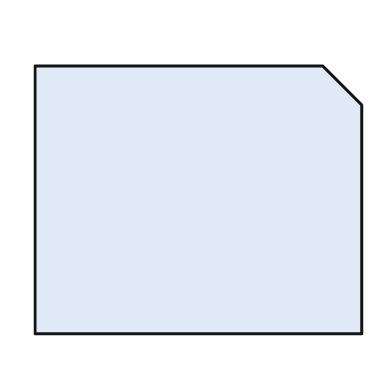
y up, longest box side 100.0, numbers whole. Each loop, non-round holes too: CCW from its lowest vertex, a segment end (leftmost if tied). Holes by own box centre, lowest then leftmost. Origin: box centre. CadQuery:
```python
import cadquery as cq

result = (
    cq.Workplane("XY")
    .moveTo(-50.0, -41.0)
    .lineTo(50.0, -41.0)
    .lineTo(50.0, 29.0)
    .lineTo(38.0, 41.0)
    .lineTo(-50.0, 41.0)
    .close()
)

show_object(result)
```